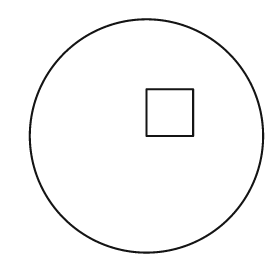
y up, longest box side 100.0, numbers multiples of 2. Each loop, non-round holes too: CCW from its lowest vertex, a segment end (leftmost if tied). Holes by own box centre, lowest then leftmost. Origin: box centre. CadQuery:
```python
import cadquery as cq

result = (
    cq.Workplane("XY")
    .moveTo(0.0, 0.0)
    .circle(50.0)
    .moveTo(0.0, 0.0)
    .lineTo(20.0, 0.0)
    .lineTo(20.0, 20.0)
    .lineTo(0.0, 20.0)
    .close()
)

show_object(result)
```